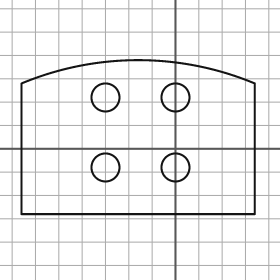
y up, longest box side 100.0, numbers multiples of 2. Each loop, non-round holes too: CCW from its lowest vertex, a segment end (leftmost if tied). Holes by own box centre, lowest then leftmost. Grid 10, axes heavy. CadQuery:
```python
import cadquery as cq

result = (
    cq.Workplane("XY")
    .moveTo(-66.0, -28.0)
    .lineTo(34.0, -28.0)
    .lineTo(34.0, 28.0)
    .threePointArc((-16.0, 38.0), (-66.0, 28.0))
    .close()
    .moveTo(-30.0, -8.0)
    .circle(6.0)
    .moveTo(0.0, -8.0)
    .circle(6.0)
    .moveTo(-30.0, 22.0)
    .circle(6.0)
    .moveTo(0.0, 22.0)
    .circle(6.0)
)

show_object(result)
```